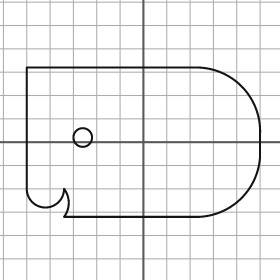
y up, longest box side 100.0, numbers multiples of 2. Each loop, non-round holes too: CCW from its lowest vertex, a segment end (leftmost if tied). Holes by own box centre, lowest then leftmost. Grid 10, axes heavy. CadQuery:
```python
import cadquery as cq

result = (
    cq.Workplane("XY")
    .moveTo(-34.0, -32.0)
    .lineTo(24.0, -32.0)
    .threePointArc((42.0, -24.0), (50.0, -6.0))
    .lineTo(50.0, 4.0)
    .threePointArc((42.0, 24.0), (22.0, 32.0))
    .lineTo(-50.0, 32.0)
    .lineTo(-50.0, -20.0)
    .threePointArc((-42.0, -28.0), (-34.0, -20.0))
    .threePointArc((-32.0, -26.0), (-34.0, -32.0))
    .close()
    .moveTo(-26.0, 2.0)
    .circle(4.0)
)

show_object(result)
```